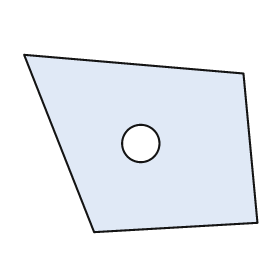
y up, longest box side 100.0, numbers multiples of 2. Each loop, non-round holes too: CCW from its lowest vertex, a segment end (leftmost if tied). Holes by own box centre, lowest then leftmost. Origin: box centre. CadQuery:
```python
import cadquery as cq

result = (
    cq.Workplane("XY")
    .moveTo(-20.0, -38.0)
    .lineTo(50.0, -34.0)
    .lineTo(44.0, 30.0)
    .lineTo(-50.0, 38.0)
    .close()
    .moveTo(0.0, 0.0)
    .circle(8.0)
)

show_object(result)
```